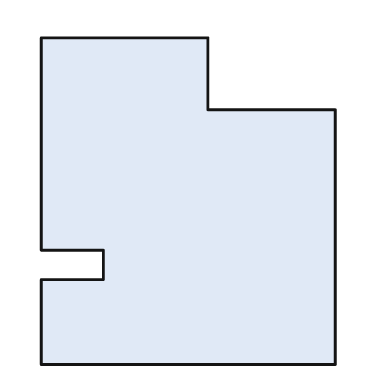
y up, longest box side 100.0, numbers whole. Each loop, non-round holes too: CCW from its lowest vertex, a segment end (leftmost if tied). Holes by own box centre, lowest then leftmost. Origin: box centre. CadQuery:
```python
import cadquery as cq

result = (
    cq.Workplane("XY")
    .moveTo(-45.0, -50.0)
    .lineTo(45.0, -50.0)
    .lineTo(45.0, 28.0)
    .lineTo(6.0, 28.0)
    .lineTo(6.0, 50.0)
    .lineTo(-45.0, 50.0)
    .lineTo(-45.0, -15.0)
    .lineTo(-26.0, -15.0)
    .lineTo(-26.0, -24.0)
    .lineTo(-45.0, -24.0)
    .close()
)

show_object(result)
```